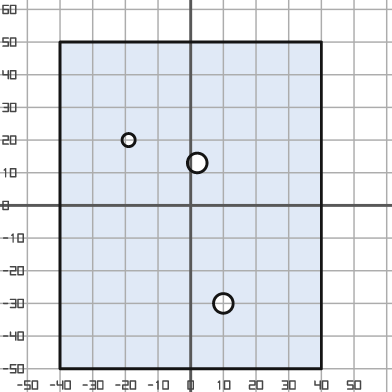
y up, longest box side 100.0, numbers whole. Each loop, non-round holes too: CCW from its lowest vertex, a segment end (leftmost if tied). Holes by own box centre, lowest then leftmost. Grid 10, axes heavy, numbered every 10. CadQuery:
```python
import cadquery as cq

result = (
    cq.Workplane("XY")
    .moveTo(-40.0, -50.0)
    .lineTo(40.0, -50.0)
    .lineTo(40.0, 50.0)
    .lineTo(-40.0, 50.0)
    .close()
    .moveTo(10.0, -30.0)
    .circle(3.0)
    .moveTo(2.0, 13.0)
    .circle(3.0)
    .moveTo(-19.0, 20.0)
    .circle(2.0)
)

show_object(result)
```